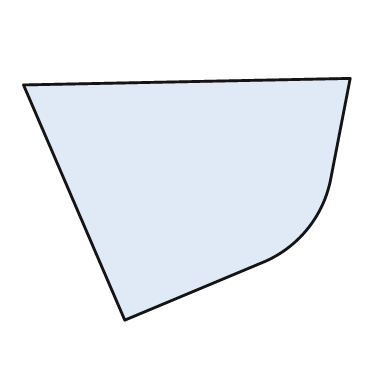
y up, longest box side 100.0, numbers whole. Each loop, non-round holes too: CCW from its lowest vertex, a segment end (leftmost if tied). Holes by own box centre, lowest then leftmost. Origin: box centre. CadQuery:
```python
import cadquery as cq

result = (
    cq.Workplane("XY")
    .moveTo(-19.0, -37.0)
    .lineTo(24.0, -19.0)
    .threePointArc((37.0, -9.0), (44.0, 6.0))
    .lineTo(50.0, 37.0)
    .lineTo(-50.0, 35.0)
    .close()
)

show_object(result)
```